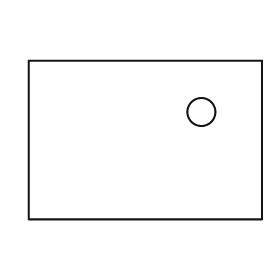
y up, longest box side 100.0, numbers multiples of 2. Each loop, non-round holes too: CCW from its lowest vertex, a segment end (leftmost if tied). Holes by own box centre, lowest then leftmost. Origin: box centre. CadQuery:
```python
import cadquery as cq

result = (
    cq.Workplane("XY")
    .moveTo(-50.0, -34.0)
    .lineTo(50.0, -34.0)
    .lineTo(50.0, 34.0)
    .lineTo(-50.0, 34.0)
    .close()
    .moveTo(24.0, 12.0)
    .circle(6.0)
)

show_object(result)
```